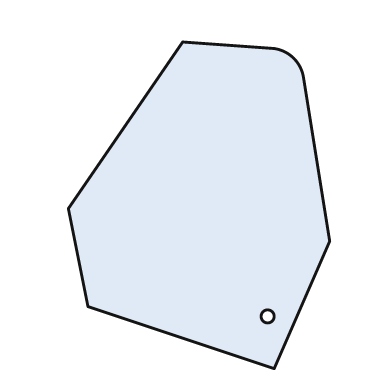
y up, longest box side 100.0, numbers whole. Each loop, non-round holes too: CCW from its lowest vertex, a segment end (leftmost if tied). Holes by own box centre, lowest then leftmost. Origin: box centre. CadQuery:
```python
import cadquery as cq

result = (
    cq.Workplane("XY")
    .moveTo(23.0, -50.0)
    .lineTo(40.0, -11.0)
    .lineTo(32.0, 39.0)
    .threePointArc((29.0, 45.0), (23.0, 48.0))
    .lineTo(-5.0, 50.0)
    .lineTo(-40.0, -1.0)
    .lineTo(-34.0, -31.0)
    .close()
    .moveTo(21.0, -34.0)
    .circle(2.0)
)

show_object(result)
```